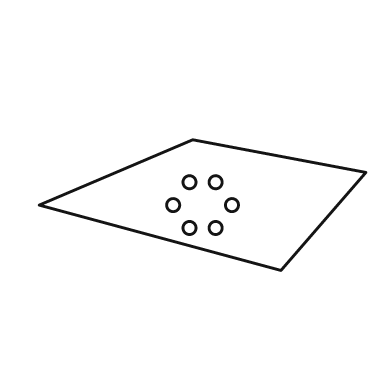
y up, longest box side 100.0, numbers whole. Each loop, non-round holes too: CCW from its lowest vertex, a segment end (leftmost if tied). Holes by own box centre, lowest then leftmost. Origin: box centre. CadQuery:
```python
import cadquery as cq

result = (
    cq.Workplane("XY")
    .moveTo(24.0, -20.0)
    .lineTo(50.0, 10.0)
    .lineTo(-3.0, 20.0)
    .lineTo(-50.0, 0.0)
    .close()
    .moveTo(-4.0, -7.0)
    .circle(2.0)
    .moveTo(4.0, -7.0)
    .circle(2.0)
    .moveTo(-9.0, 0.0)
    .circle(2.0)
    .moveTo(9.0, 0.0)
    .circle(2.0)
    .moveTo(-4.0, 7.0)
    .circle(2.0)
    .moveTo(4.0, 7.0)
    .circle(2.0)
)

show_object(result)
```